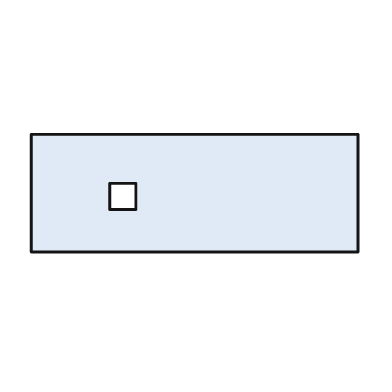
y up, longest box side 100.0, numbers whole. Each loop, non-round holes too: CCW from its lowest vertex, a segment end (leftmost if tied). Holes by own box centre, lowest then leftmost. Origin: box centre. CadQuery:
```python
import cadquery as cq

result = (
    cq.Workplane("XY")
    .moveTo(-50.0, -18.0)
    .lineTo(50.0, -18.0)
    .lineTo(50.0, 18.0)
    .lineTo(-50.0, 18.0)
    .close()
    .moveTo(-26.0, -5.0)
    .lineTo(-18.0, -5.0)
    .lineTo(-18.0, 3.0)
    .lineTo(-26.0, 3.0)
    .close()
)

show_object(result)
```